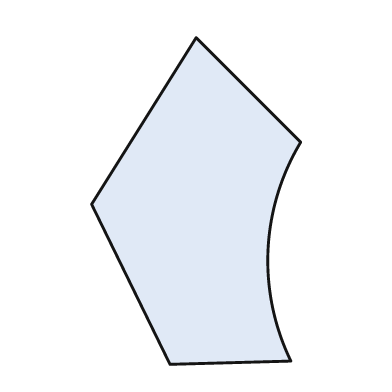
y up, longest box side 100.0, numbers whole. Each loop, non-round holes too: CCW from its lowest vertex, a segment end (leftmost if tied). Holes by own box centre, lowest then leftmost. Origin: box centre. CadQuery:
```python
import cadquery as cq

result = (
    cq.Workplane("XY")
    .moveTo(-8.0, -50.0)
    .lineTo(29.0, -49.0)
    .threePointArc((22.0, -15.0), (32.0, 18.0))
    .lineTo(0.0, 50.0)
    .lineTo(-32.0, -1.0)
    .close()
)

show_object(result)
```